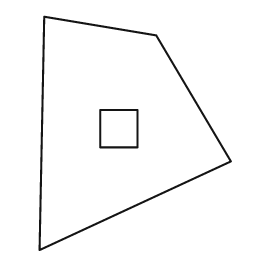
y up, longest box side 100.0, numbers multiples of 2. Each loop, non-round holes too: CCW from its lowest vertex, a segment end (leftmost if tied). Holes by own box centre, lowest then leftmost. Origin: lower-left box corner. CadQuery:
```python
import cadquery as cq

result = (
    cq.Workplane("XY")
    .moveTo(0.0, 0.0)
    .lineTo(82.0, 38.0)
    .lineTo(50.0, 92.0)
    .lineTo(2.0, 100.0)
    .close()
    .moveTo(26.0, 44.0)
    .lineTo(42.0, 44.0)
    .lineTo(42.0, 60.0)
    .lineTo(26.0, 60.0)
    .close()
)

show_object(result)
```